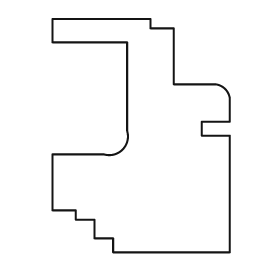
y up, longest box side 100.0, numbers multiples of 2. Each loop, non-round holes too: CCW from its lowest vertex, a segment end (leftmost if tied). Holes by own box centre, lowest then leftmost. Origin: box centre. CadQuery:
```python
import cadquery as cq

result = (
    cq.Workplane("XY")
    .moveTo(-12.0, -50.0)
    .lineTo(38.0, -50.0)
    .lineTo(38.0, 0.0)
    .lineTo(26.0, 0.0)
    .lineTo(26.0, 6.0)
    .lineTo(38.0, 6.0)
    .lineTo(38.0, 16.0)
    .threePointArc((36.0, 20.0), (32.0, 22.0))
    .lineTo(14.0, 22.0)
    .lineTo(14.0, 46.0)
    .lineTo(4.0, 46.0)
    .lineTo(4.0, 50.0)
    .lineTo(-38.0, 50.0)
    .lineTo(-38.0, 40.0)
    .lineTo(-6.0, 40.0)
    .lineTo(-6.0, 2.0)
    .threePointArc((-8.0, -6.0), (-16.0, -8.0))
    .lineTo(-38.0, -8.0)
    .lineTo(-38.0, -32.0)
    .lineTo(-28.0, -32.0)
    .lineTo(-28.0, -36.0)
    .lineTo(-20.0, -36.0)
    .lineTo(-20.0, -44.0)
    .lineTo(-12.0, -44.0)
    .close()
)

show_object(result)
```